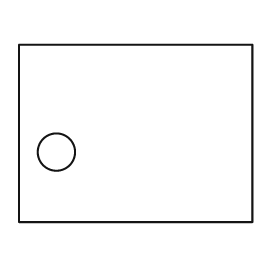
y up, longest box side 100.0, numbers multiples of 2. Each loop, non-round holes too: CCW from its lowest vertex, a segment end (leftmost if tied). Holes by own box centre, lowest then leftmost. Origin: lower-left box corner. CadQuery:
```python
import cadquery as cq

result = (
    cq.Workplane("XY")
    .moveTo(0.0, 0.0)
    .lineTo(100.0, 0.0)
    .lineTo(100.0, 76.0)
    .lineTo(0.0, 76.0)
    .close()
    .moveTo(16.0, 30.0)
    .circle(8.0)
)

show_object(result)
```